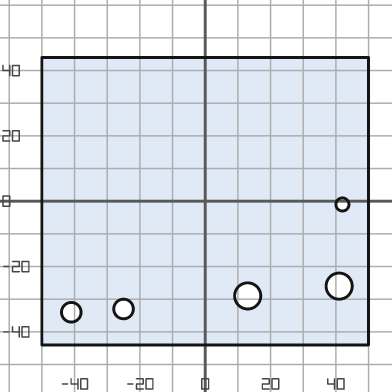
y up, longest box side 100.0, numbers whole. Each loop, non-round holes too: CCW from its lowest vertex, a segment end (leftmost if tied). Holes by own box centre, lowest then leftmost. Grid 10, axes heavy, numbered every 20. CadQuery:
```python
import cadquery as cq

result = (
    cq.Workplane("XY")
    .moveTo(-50.0, -44.0)
    .lineTo(50.0, -44.0)
    .lineTo(50.0, 44.0)
    .lineTo(-50.0, 44.0)
    .close()
    .moveTo(-41.0, -34.0)
    .circle(3.0)
    .moveTo(-25.0, -33.0)
    .circle(3.0)
    .moveTo(13.0, -29.0)
    .circle(4.0)
    .moveTo(41.0, -26.0)
    .circle(4.0)
    .moveTo(42.0, -1.0)
    .circle(2.0)
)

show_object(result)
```